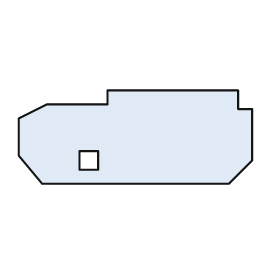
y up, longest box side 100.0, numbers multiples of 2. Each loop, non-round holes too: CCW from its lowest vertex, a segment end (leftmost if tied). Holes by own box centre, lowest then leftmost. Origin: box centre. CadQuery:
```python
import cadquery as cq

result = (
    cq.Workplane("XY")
    .moveTo(-40.0, -20.0)
    .lineTo(40.0, -20.0)
    .lineTo(50.0, -10.0)
    .lineTo(50.0, 12.0)
    .lineTo(44.0, 12.0)
    .lineTo(44.0, 20.0)
    .lineTo(-12.0, 20.0)
    .lineTo(-12.0, 14.0)
    .lineTo(-38.0, 14.0)
    .lineTo(-50.0, 8.0)
    .lineTo(-50.0, -8.0)
    .close()
    .moveTo(-24.0, -14.0)
    .lineTo(-16.0, -14.0)
    .lineTo(-16.0, -6.0)
    .lineTo(-24.0, -6.0)
    .close()
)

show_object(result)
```